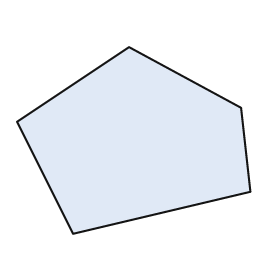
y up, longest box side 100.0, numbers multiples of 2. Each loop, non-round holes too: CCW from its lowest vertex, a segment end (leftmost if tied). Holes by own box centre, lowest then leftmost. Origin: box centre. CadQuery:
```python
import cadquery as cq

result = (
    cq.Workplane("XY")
    .moveTo(-26.0, -40.0)
    .lineTo(50.0, -22.0)
    .lineTo(46.0, 14.0)
    .lineTo(-2.0, 40.0)
    .lineTo(-50.0, 8.0)
    .close()
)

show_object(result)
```